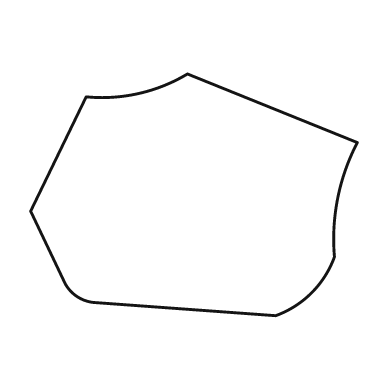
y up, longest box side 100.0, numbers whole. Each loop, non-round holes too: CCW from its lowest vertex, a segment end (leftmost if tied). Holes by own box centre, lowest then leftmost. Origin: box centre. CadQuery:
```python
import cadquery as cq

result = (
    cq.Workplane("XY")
    .moveTo(25.0, -37.0)
    .threePointArc((36.0, -30.0), (43.0, -19.0))
    .threePointArc((44.0, -1.0), (50.0, 16.0))
    .lineTo(-2.0, 37.0)
    .threePointArc((-17.0, 31.0), (-33.0, 30.0))
    .lineTo(-50.0, -5.0)
    .lineTo(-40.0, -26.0)
    .threePointArc((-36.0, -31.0), (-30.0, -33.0))
    .close()
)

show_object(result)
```